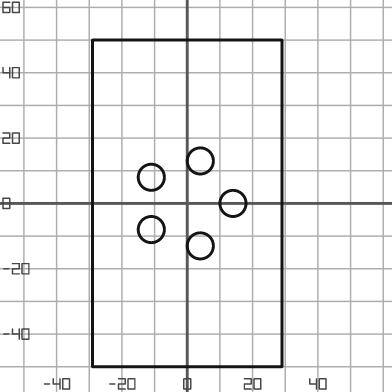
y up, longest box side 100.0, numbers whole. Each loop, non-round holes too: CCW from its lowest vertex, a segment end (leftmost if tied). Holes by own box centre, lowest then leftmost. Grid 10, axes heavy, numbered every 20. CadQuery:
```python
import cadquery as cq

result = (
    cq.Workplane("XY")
    .moveTo(-29.0, -50.0)
    .lineTo(29.0, -50.0)
    .lineTo(29.0, 50.0)
    .lineTo(-29.0, 50.0)
    .close()
    .moveTo(4.0, -13.0)
    .circle(4.0)
    .moveTo(-11.0, -8.0)
    .circle(4.0)
    .moveTo(14.0, 0.0)
    .circle(4.0)
    .moveTo(-11.0, 8.0)
    .circle(4.0)
    .moveTo(4.0, 13.0)
    .circle(4.0)
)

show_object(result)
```